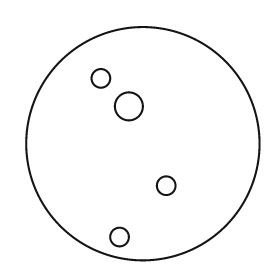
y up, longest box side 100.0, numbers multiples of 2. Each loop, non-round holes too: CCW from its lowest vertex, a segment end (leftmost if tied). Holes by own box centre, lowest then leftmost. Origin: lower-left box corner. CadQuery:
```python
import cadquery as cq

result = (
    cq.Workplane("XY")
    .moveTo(50.0, 50.0)
    .circle(50.0)
    .moveTo(40.0, 10.0)
    .circle(4.0)
    .moveTo(60.0, 32.0)
    .circle(4.0)
    .moveTo(44.0, 66.0)
    .circle(6.0)
    .moveTo(32.0, 78.0)
    .circle(4.0)
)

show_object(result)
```